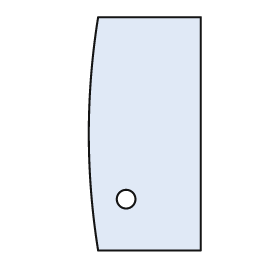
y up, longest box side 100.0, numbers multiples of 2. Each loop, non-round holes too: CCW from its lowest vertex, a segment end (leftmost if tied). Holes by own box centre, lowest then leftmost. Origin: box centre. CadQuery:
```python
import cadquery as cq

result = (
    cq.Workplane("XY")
    .moveTo(-20.0, -50.0)
    .lineTo(24.0, -50.0)
    .lineTo(24.0, 50.0)
    .lineTo(-20.0, 50.0)
    .threePointArc((-24.0, 0.0), (-20.0, -50.0))
    .close()
    .moveTo(-8.0, -28.0)
    .circle(4.0)
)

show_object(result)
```